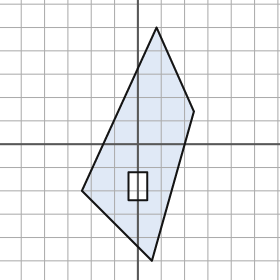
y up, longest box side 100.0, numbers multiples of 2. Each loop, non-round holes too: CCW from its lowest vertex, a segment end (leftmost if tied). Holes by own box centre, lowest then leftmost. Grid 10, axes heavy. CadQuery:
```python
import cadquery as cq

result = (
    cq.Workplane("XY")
    .moveTo(6.0, -50.0)
    .lineTo(24.0, 14.0)
    .lineTo(8.0, 50.0)
    .lineTo(-24.0, -20.0)
    .close()
    .moveTo(-4.0, -24.0)
    .lineTo(4.0, -24.0)
    .lineTo(4.0, -12.0)
    .lineTo(-4.0, -12.0)
    .close()
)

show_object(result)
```